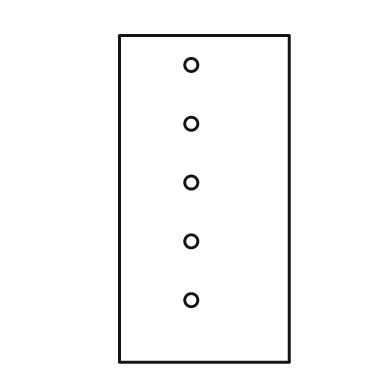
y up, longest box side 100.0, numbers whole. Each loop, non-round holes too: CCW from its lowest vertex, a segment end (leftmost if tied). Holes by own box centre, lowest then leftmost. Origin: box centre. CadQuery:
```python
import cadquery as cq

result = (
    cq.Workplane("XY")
    .moveTo(-26.0, -50.0)
    .lineTo(26.0, -50.0)
    .lineTo(26.0, 50.0)
    .lineTo(-26.0, 50.0)
    .close()
    .moveTo(-4.0, -31.0)
    .circle(2.0)
    .moveTo(-4.0, -13.0)
    .circle(2.0)
    .moveTo(-4.0, 5.0)
    .circle(2.0)
    .moveTo(-4.0, 23.0)
    .circle(2.0)
    .moveTo(-4.0, 41.0)
    .circle(2.0)
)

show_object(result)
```